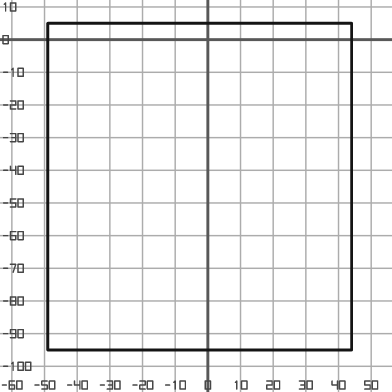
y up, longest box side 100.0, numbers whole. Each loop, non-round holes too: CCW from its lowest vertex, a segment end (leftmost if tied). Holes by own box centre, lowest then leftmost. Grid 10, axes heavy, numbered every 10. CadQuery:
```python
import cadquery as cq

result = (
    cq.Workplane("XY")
    .moveTo(-49.0, -95.0)
    .lineTo(44.0, -95.0)
    .lineTo(44.0, 5.0)
    .lineTo(-49.0, 5.0)
    .close()
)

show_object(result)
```